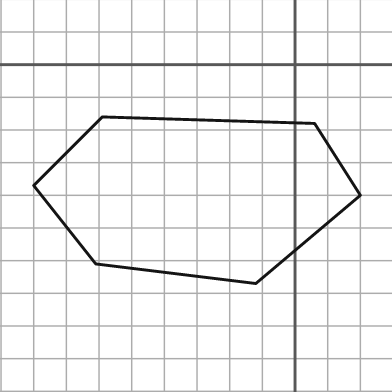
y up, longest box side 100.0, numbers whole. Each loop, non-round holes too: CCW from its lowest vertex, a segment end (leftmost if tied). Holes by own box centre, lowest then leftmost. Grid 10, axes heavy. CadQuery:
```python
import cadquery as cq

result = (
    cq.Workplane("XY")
    .moveTo(-12.0, -67.0)
    .lineTo(20.0, -40.0)
    .lineTo(6.0, -18.0)
    .lineTo(-59.0, -16.0)
    .lineTo(-80.0, -37.0)
    .lineTo(-61.0, -61.0)
    .close()
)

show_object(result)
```